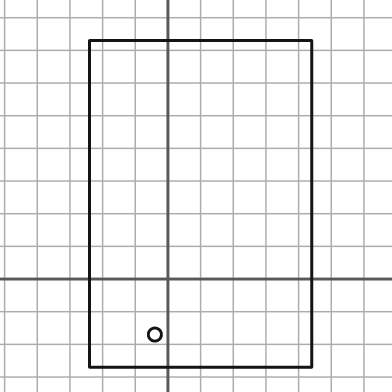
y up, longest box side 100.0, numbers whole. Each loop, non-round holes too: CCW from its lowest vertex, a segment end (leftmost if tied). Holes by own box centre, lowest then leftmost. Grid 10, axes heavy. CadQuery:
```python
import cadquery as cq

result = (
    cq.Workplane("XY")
    .moveTo(-24.0, -27.0)
    .lineTo(44.0, -27.0)
    .lineTo(44.0, 73.0)
    .lineTo(-24.0, 73.0)
    .close()
    .moveTo(-4.0, -17.0)
    .circle(2.0)
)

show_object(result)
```